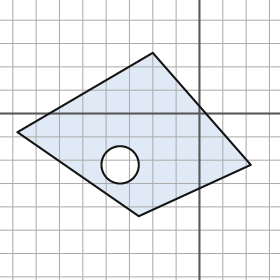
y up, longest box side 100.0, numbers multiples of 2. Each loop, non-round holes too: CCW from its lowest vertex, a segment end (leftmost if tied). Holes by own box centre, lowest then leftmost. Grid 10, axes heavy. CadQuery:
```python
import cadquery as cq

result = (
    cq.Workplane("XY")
    .moveTo(-26.0, -44.0)
    .lineTo(22.0, -22.0)
    .lineTo(-20.0, 26.0)
    .lineTo(-78.0, -8.0)
    .close()
    .moveTo(-34.0, -22.0)
    .circle(8.0)
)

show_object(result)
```